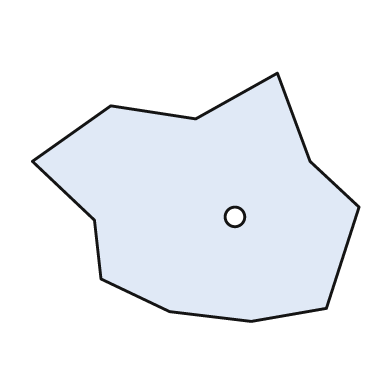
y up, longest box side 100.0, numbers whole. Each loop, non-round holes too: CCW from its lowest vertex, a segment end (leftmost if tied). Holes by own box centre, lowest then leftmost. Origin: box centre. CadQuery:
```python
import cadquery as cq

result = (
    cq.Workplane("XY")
    .moveTo(17.0, -38.0)
    .lineTo(40.0, -34.0)
    .lineTo(50.0, -3.0)
    .lineTo(35.0, 11.0)
    .lineTo(25.0, 38.0)
    .lineTo(0.0, 24.0)
    .lineTo(-26.0, 28.0)
    .lineTo(-50.0, 11.0)
    .lineTo(-31.0, -7.0)
    .lineTo(-29.0, -25.0)
    .lineTo(-8.0, -35.0)
    .close()
    .moveTo(12.0, -6.0)
    .circle(3.0)
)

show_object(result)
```